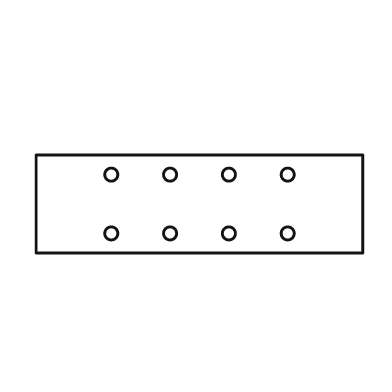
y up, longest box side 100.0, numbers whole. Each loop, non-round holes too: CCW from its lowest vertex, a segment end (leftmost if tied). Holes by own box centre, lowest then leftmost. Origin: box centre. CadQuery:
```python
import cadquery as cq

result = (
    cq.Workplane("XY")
    .moveTo(-50.0, -15.0)
    .lineTo(50.0, -15.0)
    .lineTo(50.0, 15.0)
    .lineTo(-50.0, 15.0)
    .close()
    .moveTo(-27.0, -9.0)
    .circle(2.0)
    .moveTo(-9.0, -9.0)
    .circle(2.0)
    .moveTo(9.0, -9.0)
    .circle(2.0)
    .moveTo(27.0, -9.0)
    .circle(2.0)
    .moveTo(-27.0, 9.0)
    .circle(2.0)
    .moveTo(-9.0, 9.0)
    .circle(2.0)
    .moveTo(9.0, 9.0)
    .circle(2.0)
    .moveTo(27.0, 9.0)
    .circle(2.0)
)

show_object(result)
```